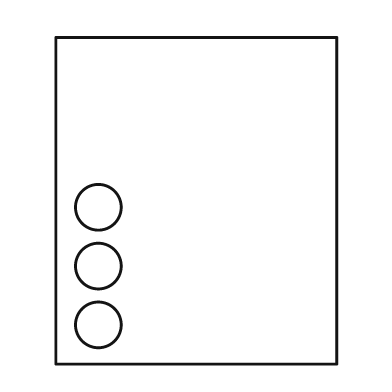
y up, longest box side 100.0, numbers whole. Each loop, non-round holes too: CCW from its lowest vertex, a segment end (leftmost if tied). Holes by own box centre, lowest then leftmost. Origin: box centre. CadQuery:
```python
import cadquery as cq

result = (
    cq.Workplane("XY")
    .moveTo(-43.0, -50.0)
    .lineTo(43.0, -50.0)
    .lineTo(43.0, 50.0)
    .lineTo(-43.0, 50.0)
    .close()
    .moveTo(-30.0, -38.0)
    .circle(7.0)
    .moveTo(-30.0, -20.0)
    .circle(7.0)
    .moveTo(-30.0, -2.0)
    .circle(7.0)
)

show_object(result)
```